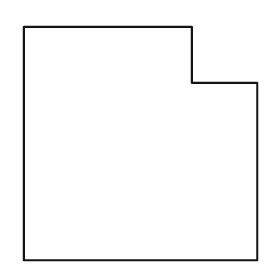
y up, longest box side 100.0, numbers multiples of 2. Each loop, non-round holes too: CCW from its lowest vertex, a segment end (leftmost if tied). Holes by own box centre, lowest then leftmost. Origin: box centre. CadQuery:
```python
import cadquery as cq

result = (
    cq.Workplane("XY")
    .moveTo(-50.0, -50.0)
    .lineTo(50.0, -50.0)
    .lineTo(50.0, 26.0)
    .lineTo(22.0, 26.0)
    .lineTo(22.0, 50.0)
    .lineTo(-50.0, 50.0)
    .close()
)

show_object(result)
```